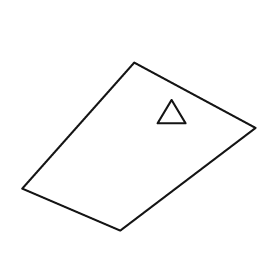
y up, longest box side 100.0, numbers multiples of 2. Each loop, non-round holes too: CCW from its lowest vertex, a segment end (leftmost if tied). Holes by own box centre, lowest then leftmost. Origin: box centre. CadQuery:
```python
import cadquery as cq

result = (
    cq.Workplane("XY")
    .moveTo(-8.0, -36.0)
    .lineTo(50.0, 8.0)
    .lineTo(-2.0, 36.0)
    .lineTo(-50.0, -18.0)
    .close()
    .moveTo(8.0, 10.0)
    .lineTo(20.0, 10.0)
    .lineTo(14.0, 20.0)
    .close()
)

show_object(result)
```